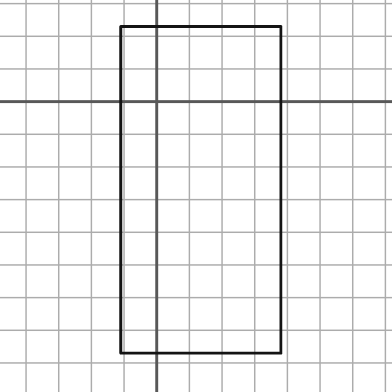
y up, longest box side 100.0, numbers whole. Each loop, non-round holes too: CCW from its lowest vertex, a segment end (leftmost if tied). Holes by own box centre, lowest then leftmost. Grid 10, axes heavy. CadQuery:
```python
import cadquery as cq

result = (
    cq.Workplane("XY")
    .moveTo(-11.0, -77.0)
    .lineTo(38.0, -77.0)
    .lineTo(38.0, 23.0)
    .lineTo(-11.0, 23.0)
    .close()
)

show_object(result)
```